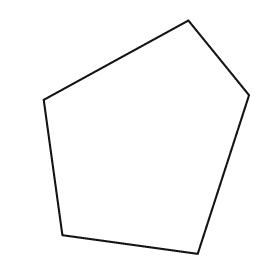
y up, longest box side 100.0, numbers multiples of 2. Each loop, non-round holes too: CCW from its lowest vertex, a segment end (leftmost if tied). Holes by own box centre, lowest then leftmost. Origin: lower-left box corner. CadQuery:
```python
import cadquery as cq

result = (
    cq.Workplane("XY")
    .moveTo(66.0, 0.0)
    .lineTo(88.0, 68.0)
    .lineTo(62.0, 100.0)
    .lineTo(0.0, 66.0)
    .lineTo(8.0, 8.0)
    .close()
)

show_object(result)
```